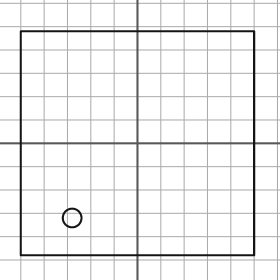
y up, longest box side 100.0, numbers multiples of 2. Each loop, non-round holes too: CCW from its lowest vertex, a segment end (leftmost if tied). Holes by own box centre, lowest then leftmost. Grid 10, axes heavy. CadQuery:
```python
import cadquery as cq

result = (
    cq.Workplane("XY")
    .moveTo(-50.0, -48.0)
    .lineTo(50.0, -48.0)
    .lineTo(50.0, 48.0)
    .lineTo(-50.0, 48.0)
    .close()
    .moveTo(-28.0, -32.0)
    .circle(4.0)
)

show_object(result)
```